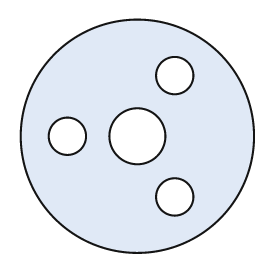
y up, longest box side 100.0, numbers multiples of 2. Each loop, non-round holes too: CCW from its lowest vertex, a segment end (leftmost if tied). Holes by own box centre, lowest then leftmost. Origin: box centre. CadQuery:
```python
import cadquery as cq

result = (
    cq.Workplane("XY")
    .moveTo(0.0, 0.0)
    .circle(50.0)
    .moveTo(16.0, -26.0)
    .circle(8.0)
    .moveTo(-30.0, 0.0)
    .circle(8.0)
    .moveTo(0.0, 0.0)
    .circle(12.0)
    .moveTo(16.0, 26.0)
    .circle(8.0)
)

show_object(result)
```